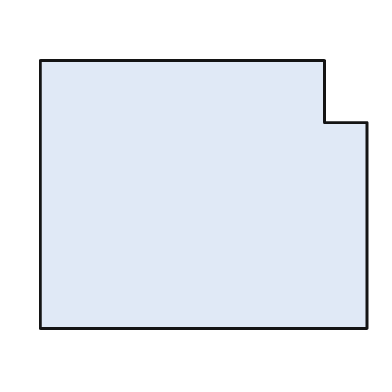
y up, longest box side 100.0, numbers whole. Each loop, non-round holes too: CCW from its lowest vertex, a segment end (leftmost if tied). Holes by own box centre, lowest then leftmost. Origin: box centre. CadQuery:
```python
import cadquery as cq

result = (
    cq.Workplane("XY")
    .moveTo(-50.0, -41.0)
    .lineTo(50.0, -41.0)
    .lineTo(50.0, 22.0)
    .lineTo(37.0, 22.0)
    .lineTo(37.0, 41.0)
    .lineTo(-50.0, 41.0)
    .close()
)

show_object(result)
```